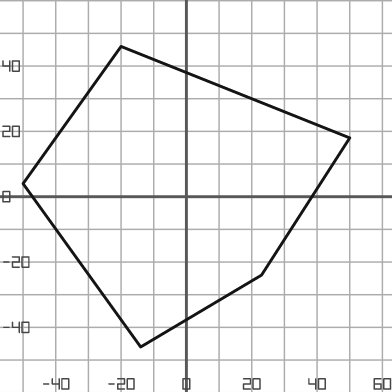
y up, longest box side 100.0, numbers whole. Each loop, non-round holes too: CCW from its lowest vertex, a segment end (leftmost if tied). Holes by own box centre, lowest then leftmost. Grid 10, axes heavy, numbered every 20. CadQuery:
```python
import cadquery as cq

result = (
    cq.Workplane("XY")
    .moveTo(-14.0, -46.0)
    .lineTo(23.0, -24.0)
    .lineTo(50.0, 18.0)
    .lineTo(-20.0, 46.0)
    .lineTo(-50.0, 4.0)
    .close()
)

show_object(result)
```